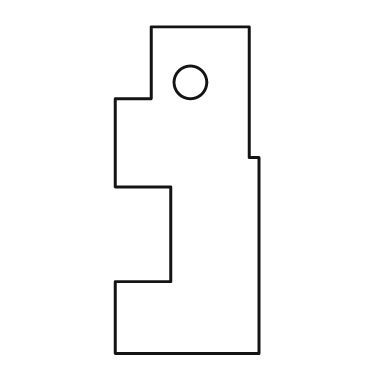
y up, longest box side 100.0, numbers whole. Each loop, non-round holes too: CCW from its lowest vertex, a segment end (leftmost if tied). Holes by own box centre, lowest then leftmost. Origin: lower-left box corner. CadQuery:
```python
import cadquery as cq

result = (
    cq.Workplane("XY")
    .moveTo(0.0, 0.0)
    .lineTo(44.0, 0.0)
    .lineTo(44.0, 60.0)
    .lineTo(41.0, 60.0)
    .lineTo(41.0, 100.0)
    .lineTo(11.0, 100.0)
    .lineTo(11.0, 78.0)
    .lineTo(0.0, 78.0)
    .lineTo(0.0, 51.0)
    .lineTo(17.0, 51.0)
    .lineTo(17.0, 22.0)
    .lineTo(0.0, 22.0)
    .close()
    .moveTo(23.0, 83.0)
    .circle(5.0)
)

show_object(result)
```